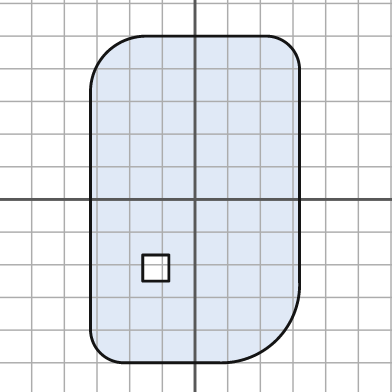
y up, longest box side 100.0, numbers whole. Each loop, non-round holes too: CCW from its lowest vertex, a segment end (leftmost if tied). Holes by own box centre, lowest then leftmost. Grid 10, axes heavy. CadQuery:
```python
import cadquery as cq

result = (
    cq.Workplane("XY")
    .moveTo(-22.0, -50.0)
    .lineTo(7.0, -50.0)
    .threePointArc((25.0, -43.0), (32.0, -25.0))
    .lineTo(32.0, 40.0)
    .threePointArc((29.0, 47.0), (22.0, 50.0))
    .lineTo(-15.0, 50.0)
    .threePointArc((-27.0, 45.0), (-32.0, 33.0))
    .lineTo(-32.0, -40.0)
    .threePointArc((-29.0, -47.0), (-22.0, -50.0))
    .close()
    .moveTo(-16.0, -25.0)
    .lineTo(-8.0, -25.0)
    .lineTo(-8.0, -17.0)
    .lineTo(-16.0, -17.0)
    .close()
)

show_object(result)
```